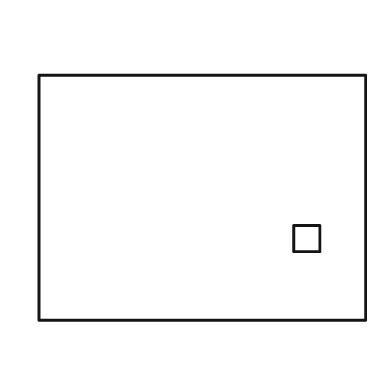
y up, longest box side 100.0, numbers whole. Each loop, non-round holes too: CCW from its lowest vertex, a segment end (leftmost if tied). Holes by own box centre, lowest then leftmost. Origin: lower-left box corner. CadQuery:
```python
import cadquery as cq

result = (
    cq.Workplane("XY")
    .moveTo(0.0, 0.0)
    .lineTo(100.0, 0.0)
    .lineTo(100.0, 75.0)
    .lineTo(0.0, 75.0)
    .close()
    .moveTo(78.0, 21.0)
    .lineTo(86.0, 21.0)
    .lineTo(86.0, 29.0)
    .lineTo(78.0, 29.0)
    .close()
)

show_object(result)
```